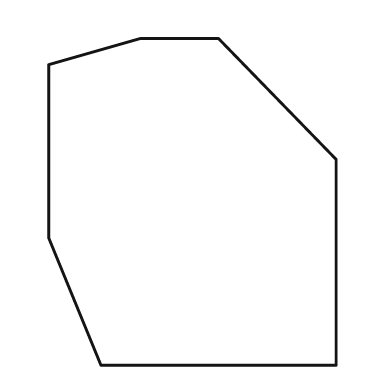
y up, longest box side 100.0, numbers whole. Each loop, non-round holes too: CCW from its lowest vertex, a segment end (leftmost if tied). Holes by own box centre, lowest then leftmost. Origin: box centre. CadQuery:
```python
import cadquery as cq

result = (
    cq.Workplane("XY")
    .moveTo(-28.0, -50.0)
    .lineTo(44.0, -50.0)
    .lineTo(44.0, 13.0)
    .lineTo(8.0, 50.0)
    .lineTo(-16.0, 50.0)
    .lineTo(-44.0, 42.0)
    .lineTo(-44.0, -11.0)
    .close()
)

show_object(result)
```